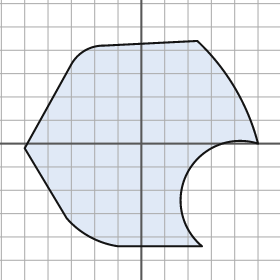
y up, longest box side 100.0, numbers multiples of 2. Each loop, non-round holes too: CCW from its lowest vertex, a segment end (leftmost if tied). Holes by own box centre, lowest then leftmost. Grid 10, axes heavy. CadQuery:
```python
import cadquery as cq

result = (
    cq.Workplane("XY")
    .moveTo(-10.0, -44.0)
    .lineTo(26.0, -44.0)
    .threePointArc((20.0, -12.0), (50.0, 0.0))
    .threePointArc((40.0, 24.0), (24.0, 44.0))
    .lineTo(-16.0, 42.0)
    .threePointArc((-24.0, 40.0), (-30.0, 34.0))
    .lineTo(-50.0, -2.0)
    .lineTo(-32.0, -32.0)
    .threePointArc((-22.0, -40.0), (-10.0, -44.0))
    .close()
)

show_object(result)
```